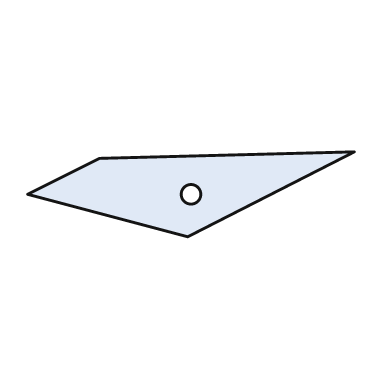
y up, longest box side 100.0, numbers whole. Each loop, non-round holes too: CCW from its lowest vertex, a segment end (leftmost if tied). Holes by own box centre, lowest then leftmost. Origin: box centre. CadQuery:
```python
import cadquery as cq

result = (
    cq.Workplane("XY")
    .moveTo(-1.0, -13.0)
    .lineTo(50.0, 13.0)
    .lineTo(-28.0, 11.0)
    .lineTo(-50.0, 0.0)
    .close()
    .moveTo(0.0, 0.0)
    .circle(3.0)
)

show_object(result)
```